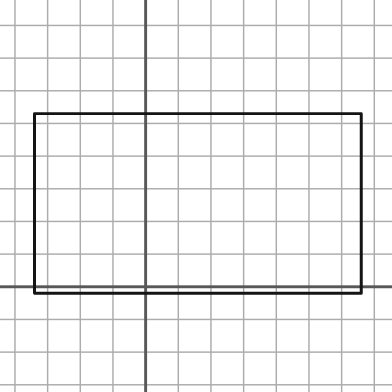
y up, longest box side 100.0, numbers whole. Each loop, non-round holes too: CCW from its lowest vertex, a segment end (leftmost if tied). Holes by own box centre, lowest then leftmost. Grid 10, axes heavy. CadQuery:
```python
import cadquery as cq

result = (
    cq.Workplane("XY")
    .moveTo(-34.0, -2.0)
    .lineTo(66.0, -2.0)
    .lineTo(66.0, 53.0)
    .lineTo(-34.0, 53.0)
    .close()
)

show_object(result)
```